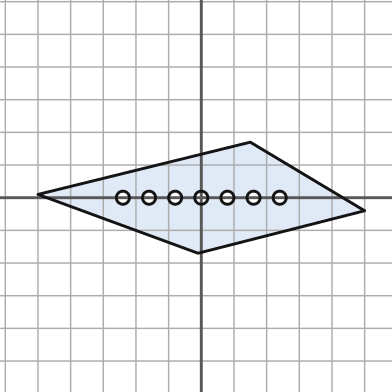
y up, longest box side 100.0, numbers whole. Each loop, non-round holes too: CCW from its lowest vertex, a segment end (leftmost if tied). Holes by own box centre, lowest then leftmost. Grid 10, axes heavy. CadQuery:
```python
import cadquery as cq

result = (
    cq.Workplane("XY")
    .moveTo(-1.0, -17.0)
    .lineTo(50.0, -4.0)
    .lineTo(15.0, 17.0)
    .lineTo(-50.0, 1.0)
    .close()
    .moveTo(-24.0, 0.0)
    .circle(2.0)
    .moveTo(-16.0, 0.0)
    .circle(2.0)
    .moveTo(-8.0, 0.0)
    .circle(2.0)
    .moveTo(0.0, 0.0)
    .circle(2.0)
    .moveTo(8.0, 0.0)
    .circle(2.0)
    .moveTo(16.0, 0.0)
    .circle(2.0)
    .moveTo(24.0, 0.0)
    .circle(2.0)
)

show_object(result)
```